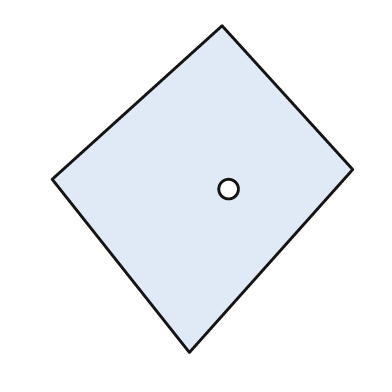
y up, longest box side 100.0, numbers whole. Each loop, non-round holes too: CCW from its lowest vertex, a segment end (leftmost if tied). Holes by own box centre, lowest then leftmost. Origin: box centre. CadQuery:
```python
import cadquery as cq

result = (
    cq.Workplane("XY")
    .moveTo(-4.0, -50.0)
    .lineTo(46.0, 6.0)
    .lineTo(6.0, 50.0)
    .lineTo(-46.0, 3.0)
    .close()
    .moveTo(8.0, 0.0)
    .circle(3.0)
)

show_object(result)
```